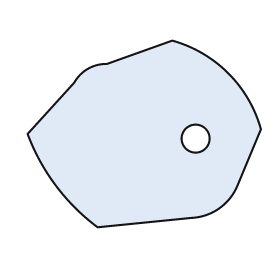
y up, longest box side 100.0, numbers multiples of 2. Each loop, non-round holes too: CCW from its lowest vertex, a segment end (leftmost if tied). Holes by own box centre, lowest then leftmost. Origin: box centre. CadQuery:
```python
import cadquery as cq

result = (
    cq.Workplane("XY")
    .moveTo(-20.0, -40.0)
    .lineTo(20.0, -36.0)
    .threePointArc((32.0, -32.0), (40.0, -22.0))
    .lineTo(50.0, 2.0)
    .threePointArc((36.0, 26.0), (12.0, 40.0))
    .lineTo(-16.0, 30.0)
    .threePointArc((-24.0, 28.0), (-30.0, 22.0))
    .lineTo(-50.0, 0.0)
    .threePointArc((-38.0, -22.0), (-20.0, -40.0))
    .close()
    .moveTo(22.0, -2.0)
    .circle(6.0)
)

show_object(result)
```